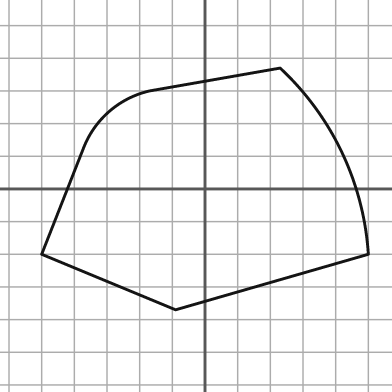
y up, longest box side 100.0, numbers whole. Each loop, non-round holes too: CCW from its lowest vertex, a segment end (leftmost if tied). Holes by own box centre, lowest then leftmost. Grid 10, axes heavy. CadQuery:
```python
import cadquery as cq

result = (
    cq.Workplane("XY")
    .moveTo(-9.0, -37.0)
    .lineTo(50.0, -20.0)
    .threePointArc((42.0, 11.0), (23.0, 37.0))
    .lineTo(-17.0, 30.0)
    .threePointArc((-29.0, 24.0), (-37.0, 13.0))
    .lineTo(-50.0, -20.0)
    .close()
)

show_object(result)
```